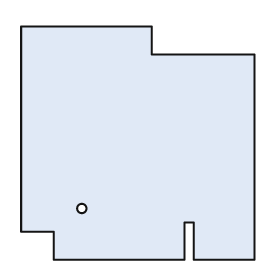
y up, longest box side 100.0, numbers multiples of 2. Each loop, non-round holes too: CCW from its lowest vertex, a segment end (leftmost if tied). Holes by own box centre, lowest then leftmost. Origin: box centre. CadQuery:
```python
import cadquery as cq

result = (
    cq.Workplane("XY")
    .moveTo(-36.0, -50.0)
    .lineTo(20.0, -50.0)
    .lineTo(20.0, -34.0)
    .lineTo(24.0, -34.0)
    .lineTo(24.0, -50.0)
    .lineTo(50.0, -50.0)
    .lineTo(50.0, 38.0)
    .lineTo(6.0, 38.0)
    .lineTo(6.0, 50.0)
    .lineTo(-50.0, 50.0)
    .lineTo(-50.0, -38.0)
    .lineTo(-36.0, -38.0)
    .close()
    .moveTo(-24.0, -28.0)
    .circle(2.0)
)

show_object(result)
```